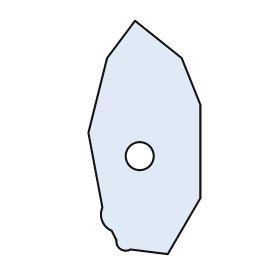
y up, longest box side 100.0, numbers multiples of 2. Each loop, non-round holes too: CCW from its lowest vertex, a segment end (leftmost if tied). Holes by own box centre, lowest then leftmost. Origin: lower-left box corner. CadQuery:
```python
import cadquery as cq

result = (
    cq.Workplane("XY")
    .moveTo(34.0, 0.0)
    .lineTo(48.0, 24.0)
    .lineTo(48.0, 64.0)
    .lineTo(40.0, 84.0)
    .lineTo(20.0, 100.0)
    .lineTo(8.0, 84.0)
    .lineTo(0.0, 52.0)
    .lineTo(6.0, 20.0)
    .threePointArc((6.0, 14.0), (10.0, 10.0))
    .lineTo(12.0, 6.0)
    .threePointArc((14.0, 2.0), (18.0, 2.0))
    .close()
    .moveTo(22.0, 42.0)
    .circle(6.0)
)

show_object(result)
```